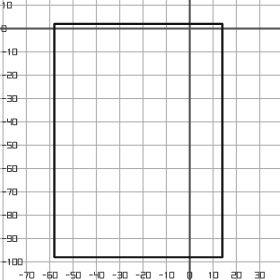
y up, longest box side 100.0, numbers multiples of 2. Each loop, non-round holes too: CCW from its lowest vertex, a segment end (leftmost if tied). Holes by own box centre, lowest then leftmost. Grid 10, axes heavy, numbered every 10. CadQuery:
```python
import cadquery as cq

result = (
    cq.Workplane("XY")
    .moveTo(-58.0, -98.0)
    .lineTo(14.0, -98.0)
    .lineTo(14.0, 2.0)
    .lineTo(-58.0, 2.0)
    .close()
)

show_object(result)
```